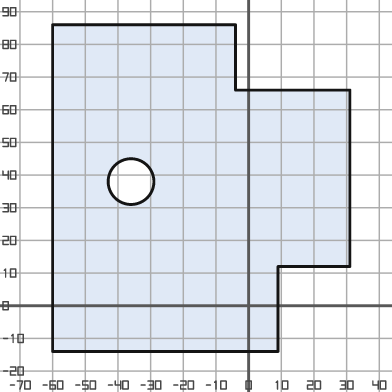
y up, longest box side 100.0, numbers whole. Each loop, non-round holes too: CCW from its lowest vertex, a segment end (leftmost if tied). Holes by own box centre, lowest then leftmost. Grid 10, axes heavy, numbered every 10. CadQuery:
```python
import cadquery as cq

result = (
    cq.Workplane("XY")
    .moveTo(-60.0, -14.0)
    .lineTo(9.0, -14.0)
    .lineTo(9.0, 12.0)
    .lineTo(31.0, 12.0)
    .lineTo(31.0, 66.0)
    .lineTo(-4.0, 66.0)
    .lineTo(-4.0, 86.0)
    .lineTo(-60.0, 86.0)
    .close()
    .moveTo(-36.0, 38.0)
    .circle(7.0)
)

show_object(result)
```